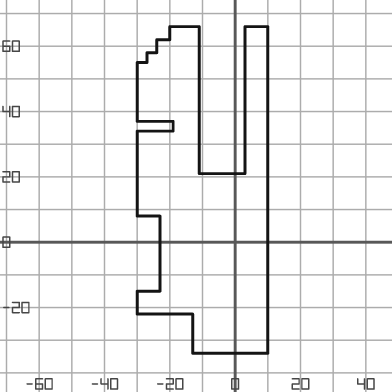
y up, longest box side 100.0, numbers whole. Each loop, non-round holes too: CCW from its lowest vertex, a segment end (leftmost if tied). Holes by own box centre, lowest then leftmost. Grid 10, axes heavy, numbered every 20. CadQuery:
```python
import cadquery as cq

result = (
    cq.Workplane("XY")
    .moveTo(-13.0, -34.0)
    .lineTo(10.0, -34.0)
    .lineTo(10.0, 66.0)
    .lineTo(3.0, 66.0)
    .lineTo(3.0, 21.0)
    .lineTo(-11.0, 21.0)
    .lineTo(-11.0, 66.0)
    .lineTo(-20.0, 66.0)
    .lineTo(-20.0, 62.0)
    .lineTo(-24.0, 62.0)
    .lineTo(-24.0, 58.0)
    .lineTo(-27.0, 58.0)
    .lineTo(-27.0, 55.0)
    .lineTo(-30.0, 55.0)
    .lineTo(-30.0, 37.0)
    .lineTo(-19.0, 37.0)
    .lineTo(-19.0, 34.0)
    .lineTo(-30.0, 34.0)
    .lineTo(-30.0, 8.0)
    .lineTo(-23.0, 8.0)
    .lineTo(-23.0, -15.0)
    .lineTo(-30.0, -15.0)
    .lineTo(-30.0, -22.0)
    .lineTo(-13.0, -22.0)
    .close()
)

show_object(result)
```